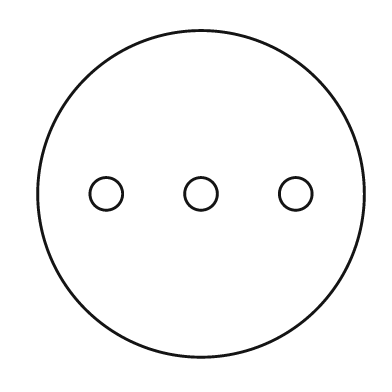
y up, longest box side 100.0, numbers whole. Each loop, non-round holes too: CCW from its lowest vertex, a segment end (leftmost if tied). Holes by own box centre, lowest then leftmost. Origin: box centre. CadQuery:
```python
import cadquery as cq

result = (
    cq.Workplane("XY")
    .moveTo(0.0, 0.0)
    .circle(50.0)
    .moveTo(-29.0, 0.0)
    .circle(5.0)
    .moveTo(0.0, 0.0)
    .circle(5.0)
    .moveTo(29.0, 0.0)
    .circle(5.0)
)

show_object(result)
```